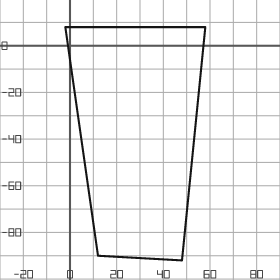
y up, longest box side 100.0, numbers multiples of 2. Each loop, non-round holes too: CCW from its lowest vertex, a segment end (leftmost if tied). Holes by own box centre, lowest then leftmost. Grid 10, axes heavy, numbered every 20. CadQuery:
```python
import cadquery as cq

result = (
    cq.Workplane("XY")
    .moveTo(48.0, -92.0)
    .lineTo(58.0, 8.0)
    .lineTo(-2.0, 8.0)
    .lineTo(12.0, -90.0)
    .close()
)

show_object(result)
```